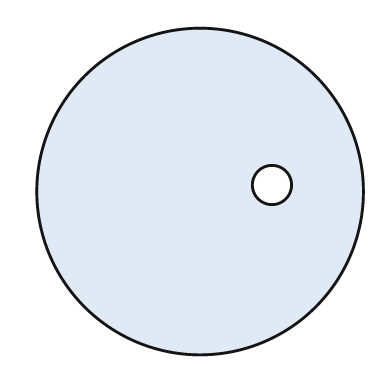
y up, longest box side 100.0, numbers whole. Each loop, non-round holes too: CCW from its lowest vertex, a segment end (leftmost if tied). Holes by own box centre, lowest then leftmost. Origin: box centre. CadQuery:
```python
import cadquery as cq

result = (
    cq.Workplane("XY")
    .moveTo(0.0, 0.0)
    .circle(50.0)
    .moveTo(22.0, 2.0)
    .circle(6.0)
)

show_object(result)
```